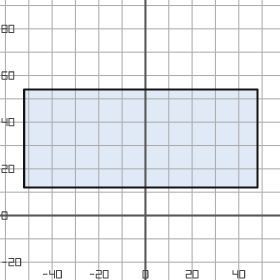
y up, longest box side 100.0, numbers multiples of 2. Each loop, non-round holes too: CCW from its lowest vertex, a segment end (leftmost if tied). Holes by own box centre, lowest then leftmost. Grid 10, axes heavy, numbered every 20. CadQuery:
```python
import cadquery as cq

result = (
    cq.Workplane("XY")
    .moveTo(-52.0, 12.0)
    .lineTo(48.0, 12.0)
    .lineTo(48.0, 54.0)
    .lineTo(-52.0, 54.0)
    .close()
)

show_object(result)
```